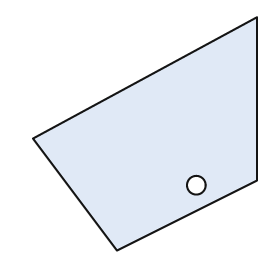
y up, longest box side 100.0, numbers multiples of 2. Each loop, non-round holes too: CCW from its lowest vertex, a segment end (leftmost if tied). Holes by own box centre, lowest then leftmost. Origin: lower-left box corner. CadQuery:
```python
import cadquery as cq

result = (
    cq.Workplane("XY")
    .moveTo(36.0, 0.0)
    .lineTo(96.0, 30.0)
    .lineTo(96.0, 100.0)
    .lineTo(0.0, 48.0)
    .close()
    .moveTo(70.0, 28.0)
    .circle(4.0)
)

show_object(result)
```